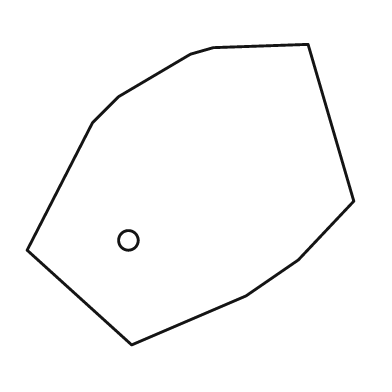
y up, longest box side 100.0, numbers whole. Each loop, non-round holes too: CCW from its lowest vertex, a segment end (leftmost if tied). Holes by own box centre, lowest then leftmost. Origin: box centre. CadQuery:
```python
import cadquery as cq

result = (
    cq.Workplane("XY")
    .moveTo(-18.0, -46.0)
    .lineTo(17.0, -31.0)
    .lineTo(33.0, -20.0)
    .lineTo(50.0, -2.0)
    .lineTo(36.0, 46.0)
    .lineTo(7.0, 45.0)
    .lineTo(0.0, 43.0)
    .lineTo(-22.0, 30.0)
    .lineTo(-30.0, 22.0)
    .lineTo(-50.0, -17.0)
    .close()
    .moveTo(-19.0, -14.0)
    .circle(3.0)
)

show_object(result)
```